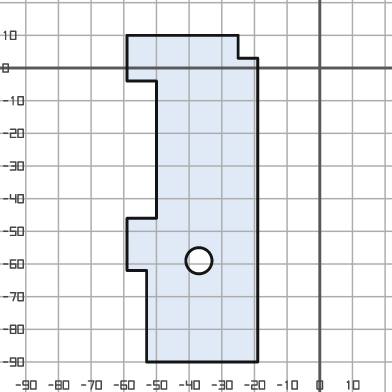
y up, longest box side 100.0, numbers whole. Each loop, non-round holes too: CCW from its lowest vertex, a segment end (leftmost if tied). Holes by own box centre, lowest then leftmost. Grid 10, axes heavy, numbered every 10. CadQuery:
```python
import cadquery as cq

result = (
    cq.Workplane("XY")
    .moveTo(-53.0, -90.0)
    .lineTo(-19.0, -90.0)
    .lineTo(-19.0, 3.0)
    .lineTo(-25.0, 3.0)
    .lineTo(-25.0, 10.0)
    .lineTo(-59.0, 10.0)
    .lineTo(-59.0, -4.0)
    .lineTo(-50.0, -4.0)
    .lineTo(-50.0, -46.0)
    .lineTo(-59.0, -46.0)
    .lineTo(-59.0, -62.0)
    .lineTo(-53.0, -62.0)
    .close()
    .moveTo(-37.0, -59.0)
    .circle(4.0)
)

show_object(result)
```